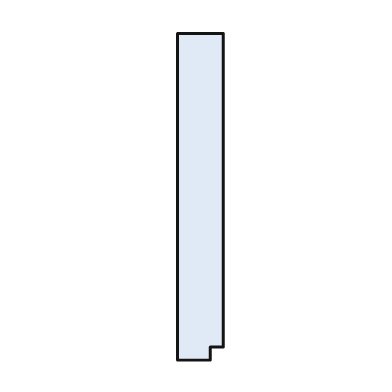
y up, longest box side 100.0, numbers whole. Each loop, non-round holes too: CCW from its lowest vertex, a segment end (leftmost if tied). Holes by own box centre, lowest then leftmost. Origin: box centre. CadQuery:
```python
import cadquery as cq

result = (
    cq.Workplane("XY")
    .moveTo(-7.0, -50.0)
    .lineTo(3.0, -50.0)
    .lineTo(3.0, -46.0)
    .lineTo(7.0, -46.0)
    .lineTo(7.0, 50.0)
    .lineTo(-7.0, 50.0)
    .close()
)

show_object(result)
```